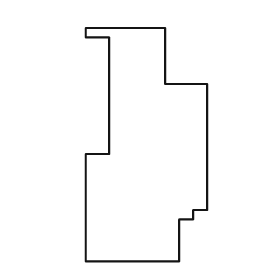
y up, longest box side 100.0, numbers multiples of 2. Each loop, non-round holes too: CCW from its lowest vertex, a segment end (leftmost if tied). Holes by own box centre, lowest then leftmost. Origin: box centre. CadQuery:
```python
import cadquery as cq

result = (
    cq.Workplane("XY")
    .moveTo(-26.0, -50.0)
    .lineTo(14.0, -50.0)
    .lineTo(14.0, -32.0)
    .lineTo(20.0, -32.0)
    .lineTo(20.0, -28.0)
    .lineTo(26.0, -28.0)
    .lineTo(26.0, 26.0)
    .lineTo(8.0, 26.0)
    .lineTo(8.0, 50.0)
    .lineTo(-26.0, 50.0)
    .lineTo(-26.0, 46.0)
    .lineTo(-16.0, 46.0)
    .lineTo(-16.0, -4.0)
    .lineTo(-26.0, -4.0)
    .close()
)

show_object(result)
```